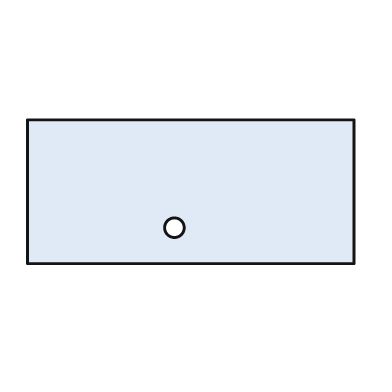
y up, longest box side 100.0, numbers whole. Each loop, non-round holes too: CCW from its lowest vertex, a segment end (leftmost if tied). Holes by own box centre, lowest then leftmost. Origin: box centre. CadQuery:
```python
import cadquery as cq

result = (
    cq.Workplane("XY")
    .moveTo(-50.0, -22.0)
    .lineTo(50.0, -22.0)
    .lineTo(50.0, 22.0)
    .lineTo(-50.0, 22.0)
    .close()
    .moveTo(-5.0, -11.0)
    .circle(3.0)
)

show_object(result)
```